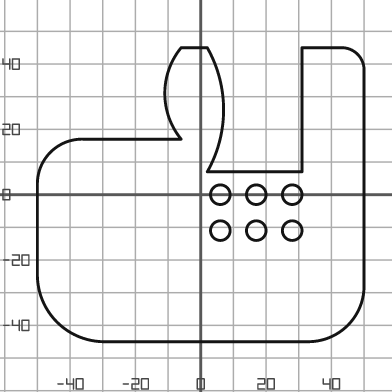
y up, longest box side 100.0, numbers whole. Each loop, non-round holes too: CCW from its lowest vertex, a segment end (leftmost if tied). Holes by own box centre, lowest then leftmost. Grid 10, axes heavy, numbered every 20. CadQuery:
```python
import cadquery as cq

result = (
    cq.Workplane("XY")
    .moveTo(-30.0, -45.0)
    .lineTo(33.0, -45.0)
    .threePointArc((45.0, -40.0), (50.0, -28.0))
    .lineTo(50.0, 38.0)
    .threePointArc((48.0, 43.0), (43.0, 45.0))
    .lineTo(31.0, 45.0)
    .lineTo(31.0, 7.0)
    .lineTo(2.0, 7.0)
    .threePointArc((7.0, 26.0), (2.0, 45.0))
    .lineTo(-6.0, 45.0)
    .threePointArc((-11.0, 31.0), (-6.0, 17.0))
    .lineTo(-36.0, 17.0)
    .threePointArc((-46.0, 13.0), (-50.0, 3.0))
    .lineTo(-50.0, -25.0)
    .threePointArc((-44.0, -39.0), (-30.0, -45.0))
    .close()
    .moveTo(6.0, -11.0)
    .circle(3.0)
    .moveTo(17.0, -11.0)
    .circle(3.0)
    .moveTo(28.0, -11.0)
    .circle(3.0)
    .moveTo(6.0, 0.0)
    .circle(3.0)
    .moveTo(17.0, 0.0)
    .circle(3.0)
    .moveTo(28.0, 0.0)
    .circle(3.0)
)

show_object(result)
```